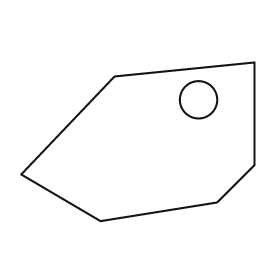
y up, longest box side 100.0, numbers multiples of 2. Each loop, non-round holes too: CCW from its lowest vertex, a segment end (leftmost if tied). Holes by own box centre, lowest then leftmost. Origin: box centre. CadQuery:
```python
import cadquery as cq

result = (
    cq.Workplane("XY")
    .moveTo(-16.0, -34.0)
    .lineTo(34.0, -26.0)
    .lineTo(50.0, -10.0)
    .lineTo(50.0, 34.0)
    .lineTo(-10.0, 28.0)
    .lineTo(-50.0, -14.0)
    .close()
    .moveTo(26.0, 18.0)
    .circle(8.0)
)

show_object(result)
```